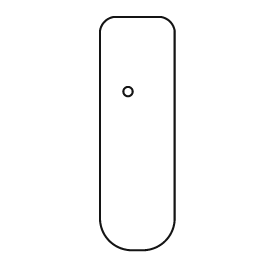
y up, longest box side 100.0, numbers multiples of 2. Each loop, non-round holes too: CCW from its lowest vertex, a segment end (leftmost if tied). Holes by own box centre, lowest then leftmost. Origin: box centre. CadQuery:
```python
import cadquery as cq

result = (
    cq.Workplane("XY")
    .moveTo(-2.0, -50.0)
    .lineTo(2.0, -50.0)
    .threePointArc((12.0, -46.0), (16.0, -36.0))
    .lineTo(16.0, 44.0)
    .threePointArc((14.0, 48.0), (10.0, 50.0))
    .lineTo(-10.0, 50.0)
    .threePointArc((-14.0, 48.0), (-16.0, 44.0))
    .lineTo(-16.0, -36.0)
    .threePointArc((-12.0, -46.0), (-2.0, -50.0))
    .close()
    .moveTo(-4.0, 18.0)
    .circle(2.0)
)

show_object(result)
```